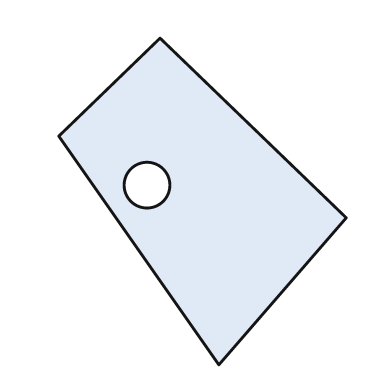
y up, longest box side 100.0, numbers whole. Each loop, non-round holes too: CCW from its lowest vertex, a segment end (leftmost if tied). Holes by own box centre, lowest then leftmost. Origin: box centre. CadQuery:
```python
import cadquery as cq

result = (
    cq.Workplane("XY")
    .moveTo(5.0, -50.0)
    .lineTo(44.0, -5.0)
    .lineTo(-13.0, 50.0)
    .lineTo(-44.0, 20.0)
    .close()
    .moveTo(-17.0, 5.0)
    .circle(7.0)
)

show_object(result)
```